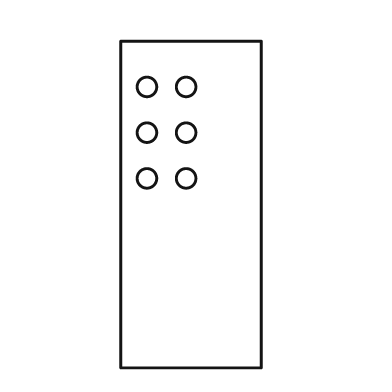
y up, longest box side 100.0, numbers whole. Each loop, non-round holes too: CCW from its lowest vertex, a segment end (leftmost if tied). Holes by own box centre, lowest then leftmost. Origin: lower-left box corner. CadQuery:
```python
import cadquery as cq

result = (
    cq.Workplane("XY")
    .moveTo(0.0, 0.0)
    .lineTo(43.0, 0.0)
    .lineTo(43.0, 100.0)
    .lineTo(0.0, 100.0)
    .close()
    .moveTo(8.0, 58.0)
    .circle(3.0)
    .moveTo(20.0, 58.0)
    .circle(3.0)
    .moveTo(8.0, 72.0)
    .circle(3.0)
    .moveTo(20.0, 72.0)
    .circle(3.0)
    .moveTo(8.0, 86.0)
    .circle(3.0)
    .moveTo(20.0, 86.0)
    .circle(3.0)
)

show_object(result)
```